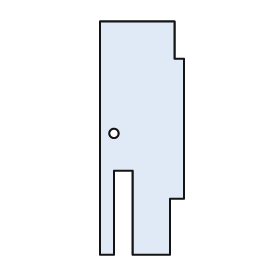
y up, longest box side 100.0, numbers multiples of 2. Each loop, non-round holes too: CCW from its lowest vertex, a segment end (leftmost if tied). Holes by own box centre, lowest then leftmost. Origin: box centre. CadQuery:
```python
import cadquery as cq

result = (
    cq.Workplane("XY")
    .moveTo(-18.0, -50.0)
    .lineTo(-12.0, -50.0)
    .lineTo(-12.0, -14.0)
    .lineTo(-4.0, -14.0)
    .lineTo(-4.0, -50.0)
    .lineTo(12.0, -50.0)
    .lineTo(12.0, -26.0)
    .lineTo(18.0, -26.0)
    .lineTo(18.0, 34.0)
    .lineTo(14.0, 34.0)
    .lineTo(14.0, 50.0)
    .lineTo(-18.0, 50.0)
    .close()
    .moveTo(-12.0, 2.0)
    .circle(2.0)
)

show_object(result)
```